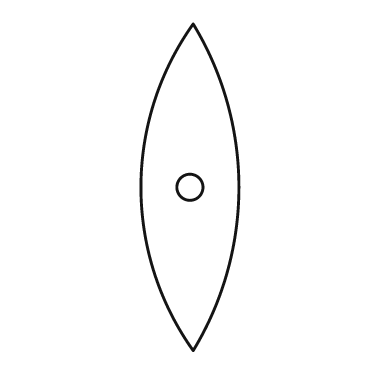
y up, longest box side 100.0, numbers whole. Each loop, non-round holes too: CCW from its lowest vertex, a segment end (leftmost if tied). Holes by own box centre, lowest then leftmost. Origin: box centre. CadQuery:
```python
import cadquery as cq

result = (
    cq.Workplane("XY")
    .moveTo(1.0, -50.0)
    .threePointArc((15.0, 0.0), (1.0, 50.0))
    .threePointArc((-15.0, 0.0), (1.0, -50.0))
    .close()
    .moveTo(0.0, 0.0)
    .circle(4.0)
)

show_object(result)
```